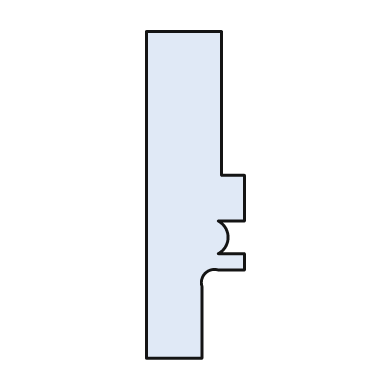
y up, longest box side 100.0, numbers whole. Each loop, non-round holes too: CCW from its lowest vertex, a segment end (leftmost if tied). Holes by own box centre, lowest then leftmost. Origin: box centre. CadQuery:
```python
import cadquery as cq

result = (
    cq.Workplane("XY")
    .moveTo(-15.0, -50.0)
    .lineTo(2.0, -50.0)
    .lineTo(2.0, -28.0)
    .threePointArc((3.0, -24.0), (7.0, -23.0))
    .lineTo(15.0, -23.0)
    .lineTo(15.0, -18.0)
    .lineTo(7.0, -18.0)
    .threePointArc((10.0, -13.0), (7.0, -8.0))
    .lineTo(15.0, -8.0)
    .lineTo(15.0, 6.0)
    .lineTo(8.0, 6.0)
    .lineTo(8.0, 50.0)
    .lineTo(-15.0, 50.0)
    .close()
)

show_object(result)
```